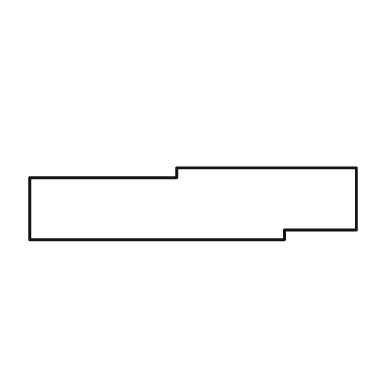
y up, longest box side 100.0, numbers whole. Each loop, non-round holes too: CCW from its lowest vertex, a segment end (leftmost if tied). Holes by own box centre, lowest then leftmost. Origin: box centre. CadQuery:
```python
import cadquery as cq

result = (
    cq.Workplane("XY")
    .moveTo(-50.0, -11.0)
    .lineTo(28.0, -11.0)
    .lineTo(28.0, -8.0)
    .lineTo(50.0, -8.0)
    .lineTo(50.0, 11.0)
    .lineTo(-5.0, 11.0)
    .lineTo(-5.0, 8.0)
    .lineTo(-50.0, 8.0)
    .close()
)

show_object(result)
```